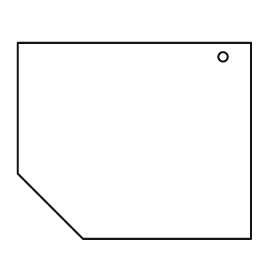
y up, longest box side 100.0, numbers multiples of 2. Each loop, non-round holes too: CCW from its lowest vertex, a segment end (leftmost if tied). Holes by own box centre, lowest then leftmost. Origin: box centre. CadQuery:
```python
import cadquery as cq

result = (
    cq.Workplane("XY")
    .moveTo(-22.0, -42.0)
    .lineTo(50.0, -42.0)
    .lineTo(50.0, 42.0)
    .lineTo(-50.0, 42.0)
    .lineTo(-50.0, -14.0)
    .close()
    .moveTo(38.0, 36.0)
    .circle(2.0)
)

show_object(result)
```